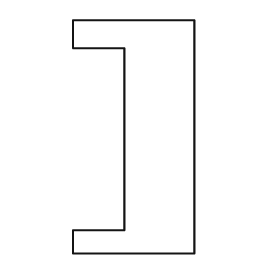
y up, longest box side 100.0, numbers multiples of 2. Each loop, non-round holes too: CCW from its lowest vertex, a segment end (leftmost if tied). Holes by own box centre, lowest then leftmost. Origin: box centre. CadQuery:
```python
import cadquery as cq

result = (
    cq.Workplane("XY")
    .moveTo(-26.0, -50.0)
    .lineTo(26.0, -50.0)
    .lineTo(26.0, 50.0)
    .lineTo(-26.0, 50.0)
    .lineTo(-26.0, 38.0)
    .lineTo(-4.0, 38.0)
    .lineTo(-4.0, -40.0)
    .lineTo(-26.0, -40.0)
    .close()
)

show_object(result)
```